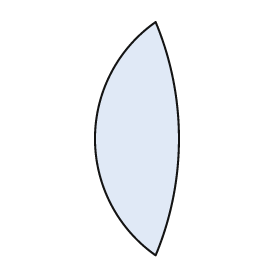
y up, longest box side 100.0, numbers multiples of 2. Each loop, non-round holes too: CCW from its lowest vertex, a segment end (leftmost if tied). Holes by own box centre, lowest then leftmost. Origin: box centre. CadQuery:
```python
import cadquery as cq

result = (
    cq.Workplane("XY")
    .moveTo(8.0, -50.0)
    .threePointArc((18.0, 0.0), (8.0, 50.0))
    .threePointArc((-18.0, 0.0), (8.0, -50.0))
    .close()
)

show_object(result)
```